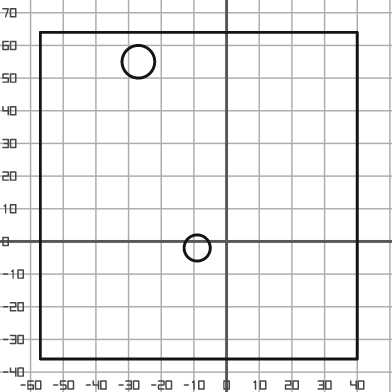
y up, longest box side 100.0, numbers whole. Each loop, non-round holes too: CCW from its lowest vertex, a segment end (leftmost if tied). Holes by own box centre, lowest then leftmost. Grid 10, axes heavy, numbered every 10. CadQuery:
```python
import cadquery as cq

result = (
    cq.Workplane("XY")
    .moveTo(-57.0, -36.0)
    .lineTo(40.0, -36.0)
    .lineTo(40.0, 64.0)
    .lineTo(-57.0, 64.0)
    .close()
    .moveTo(-9.0, -2.0)
    .circle(4.0)
    .moveTo(-27.0, 55.0)
    .circle(5.0)
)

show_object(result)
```